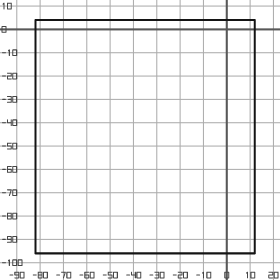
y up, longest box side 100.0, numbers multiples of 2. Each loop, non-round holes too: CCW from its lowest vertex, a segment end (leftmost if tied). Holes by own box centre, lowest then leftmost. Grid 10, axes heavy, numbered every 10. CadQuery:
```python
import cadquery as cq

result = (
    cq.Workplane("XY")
    .moveTo(-82.0, -96.0)
    .lineTo(12.0, -96.0)
    .lineTo(12.0, 4.0)
    .lineTo(-82.0, 4.0)
    .close()
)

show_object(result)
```